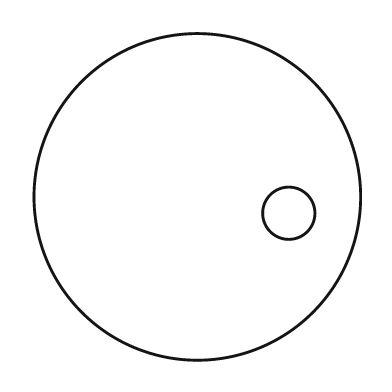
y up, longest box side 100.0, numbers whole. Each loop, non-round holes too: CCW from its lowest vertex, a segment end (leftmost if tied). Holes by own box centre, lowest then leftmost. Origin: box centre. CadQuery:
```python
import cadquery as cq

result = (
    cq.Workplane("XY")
    .moveTo(0.0, 0.0)
    .circle(50.0)
    .moveTo(28.0, -5.0)
    .circle(8.0)
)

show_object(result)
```